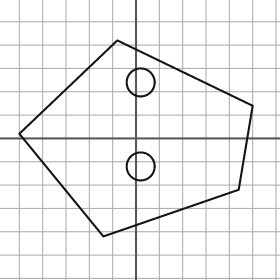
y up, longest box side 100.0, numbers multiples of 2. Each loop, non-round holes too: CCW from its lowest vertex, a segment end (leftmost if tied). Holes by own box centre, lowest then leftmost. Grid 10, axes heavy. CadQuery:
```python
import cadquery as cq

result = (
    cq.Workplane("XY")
    .moveTo(-14.0, -42.0)
    .lineTo(44.0, -22.0)
    .lineTo(50.0, 14.0)
    .lineTo(-8.0, 42.0)
    .lineTo(-50.0, 2.0)
    .close()
    .moveTo(2.0, -12.0)
    .circle(6.0)
    .moveTo(2.0, 24.0)
    .circle(6.0)
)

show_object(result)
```